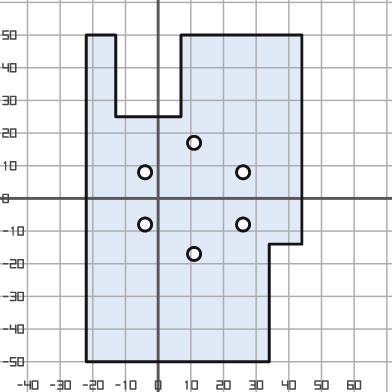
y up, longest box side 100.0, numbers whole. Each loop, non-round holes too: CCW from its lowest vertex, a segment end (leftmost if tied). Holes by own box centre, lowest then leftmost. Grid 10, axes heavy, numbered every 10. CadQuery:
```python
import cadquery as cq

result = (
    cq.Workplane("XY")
    .moveTo(-22.0, -50.0)
    .lineTo(34.0, -50.0)
    .lineTo(34.0, -14.0)
    .lineTo(44.0, -14.0)
    .lineTo(44.0, 50.0)
    .lineTo(7.0, 50.0)
    .lineTo(7.0, 25.0)
    .lineTo(-13.0, 25.0)
    .lineTo(-13.0, 50.0)
    .lineTo(-22.0, 50.0)
    .close()
    .moveTo(11.0, -17.0)
    .circle(2.0)
    .moveTo(-4.0, -8.0)
    .circle(2.0)
    .moveTo(26.0, -8.0)
    .circle(2.0)
    .moveTo(-4.0, 8.0)
    .circle(2.0)
    .moveTo(26.0, 8.0)
    .circle(2.0)
    .moveTo(11.0, 17.0)
    .circle(2.0)
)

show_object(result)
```